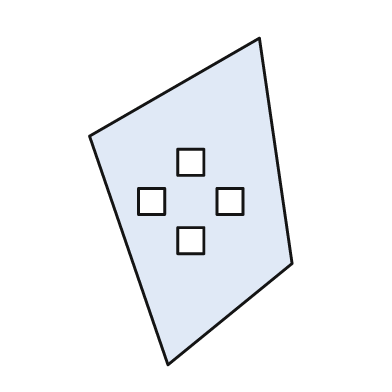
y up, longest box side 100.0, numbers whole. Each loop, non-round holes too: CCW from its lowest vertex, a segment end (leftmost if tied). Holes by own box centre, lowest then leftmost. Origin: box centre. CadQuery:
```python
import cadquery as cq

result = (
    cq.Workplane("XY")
    .moveTo(-7.0, -50.0)
    .lineTo(31.0, -19.0)
    .lineTo(21.0, 50.0)
    .lineTo(-31.0, 20.0)
    .close()
    .moveTo(-4.0, -16.0)
    .lineTo(4.0, -16.0)
    .lineTo(4.0, -8.0)
    .lineTo(-4.0, -8.0)
    .close()
    .moveTo(-16.0, -4.0)
    .lineTo(-8.0, -4.0)
    .lineTo(-8.0, 4.0)
    .lineTo(-16.0, 4.0)
    .close()
    .moveTo(8.0, -4.0)
    .lineTo(16.0, -4.0)
    .lineTo(16.0, 4.0)
    .lineTo(8.0, 4.0)
    .close()
    .moveTo(-4.0, 8.0)
    .lineTo(4.0, 8.0)
    .lineTo(4.0, 16.0)
    .lineTo(-4.0, 16.0)
    .close()
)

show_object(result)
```